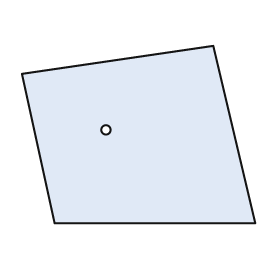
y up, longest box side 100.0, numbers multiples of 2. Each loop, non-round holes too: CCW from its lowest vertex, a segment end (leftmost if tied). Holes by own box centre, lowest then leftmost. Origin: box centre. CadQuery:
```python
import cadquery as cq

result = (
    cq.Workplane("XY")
    .moveTo(-36.0, -38.0)
    .lineTo(50.0, -38.0)
    .lineTo(32.0, 38.0)
    .lineTo(-50.0, 26.0)
    .close()
    .moveTo(-14.0, 2.0)
    .circle(2.0)
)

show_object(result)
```